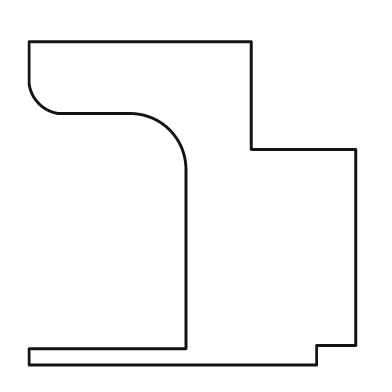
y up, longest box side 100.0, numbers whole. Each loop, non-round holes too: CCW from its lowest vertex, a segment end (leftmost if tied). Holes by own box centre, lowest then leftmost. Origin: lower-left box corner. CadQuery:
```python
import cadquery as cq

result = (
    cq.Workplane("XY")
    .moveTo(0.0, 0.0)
    .lineTo(88.0, 0.0)
    .lineTo(88.0, 6.0)
    .lineTo(100.0, 6.0)
    .lineTo(100.0, 66.0)
    .lineTo(68.0, 66.0)
    .lineTo(68.0, 99.0)
    .lineTo(0.0, 99.0)
    .lineTo(0.0, 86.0)
    .threePointArc((3.0, 80.0), (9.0, 77.0))
    .lineTo(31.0, 77.0)
    .threePointArc((43.0, 72.0), (48.0, 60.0))
    .lineTo(48.0, 5.0)
    .lineTo(0.0, 5.0)
    .close()
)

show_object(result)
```